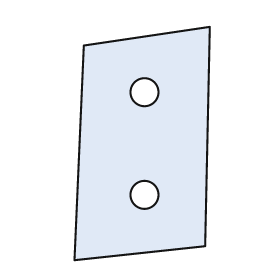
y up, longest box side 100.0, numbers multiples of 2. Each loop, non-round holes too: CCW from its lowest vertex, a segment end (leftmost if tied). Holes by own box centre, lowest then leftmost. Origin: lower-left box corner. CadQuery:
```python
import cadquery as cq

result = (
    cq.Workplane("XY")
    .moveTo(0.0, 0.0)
    .lineTo(56.0, 6.0)
    .lineTo(58.0, 100.0)
    .lineTo(4.0, 92.0)
    .close()
    .moveTo(30.0, 28.0)
    .circle(6.0)
    .moveTo(30.0, 72.0)
    .circle(6.0)
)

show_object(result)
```